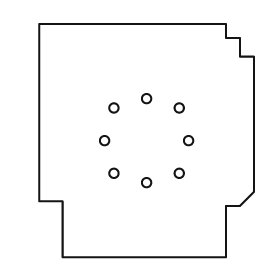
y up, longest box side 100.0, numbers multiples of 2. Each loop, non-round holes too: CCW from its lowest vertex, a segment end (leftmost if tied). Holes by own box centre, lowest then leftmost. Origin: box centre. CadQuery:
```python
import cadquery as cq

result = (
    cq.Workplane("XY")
    .moveTo(-36.0, -50.0)
    .lineTo(34.0, -50.0)
    .lineTo(34.0, -28.0)
    .lineTo(40.0, -28.0)
    .lineTo(46.0, -22.0)
    .lineTo(46.0, 36.0)
    .lineTo(40.0, 36.0)
    .lineTo(40.0, 44.0)
    .lineTo(34.0, 44.0)
    .lineTo(34.0, 50.0)
    .lineTo(-46.0, 50.0)
    .lineTo(-46.0, -26.0)
    .lineTo(-36.0, -26.0)
    .close()
    .moveTo(0.0, -18.0)
    .circle(2.0)
    .moveTo(-14.0, -14.0)
    .circle(2.0)
    .moveTo(14.0, -14.0)
    .circle(2.0)
    .moveTo(-18.0, 0.0)
    .circle(2.0)
    .moveTo(18.0, 0.0)
    .circle(2.0)
    .moveTo(-14.0, 14.0)
    .circle(2.0)
    .moveTo(14.0, 14.0)
    .circle(2.0)
    .moveTo(0.0, 18.0)
    .circle(2.0)
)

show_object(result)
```